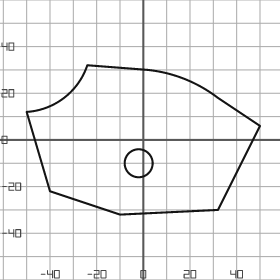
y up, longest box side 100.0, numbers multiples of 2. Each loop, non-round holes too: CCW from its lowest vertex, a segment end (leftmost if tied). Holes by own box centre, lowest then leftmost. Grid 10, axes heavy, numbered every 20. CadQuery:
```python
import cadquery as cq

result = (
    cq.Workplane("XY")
    .moveTo(-10.0, -32.0)
    .lineTo(32.0, -30.0)
    .lineTo(50.0, 6.0)
    .lineTo(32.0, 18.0)
    .threePointArc((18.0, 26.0), (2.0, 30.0))
    .lineTo(-24.0, 32.0)
    .threePointArc((-34.0, 18.0), (-50.0, 12.0))
    .lineTo(-40.0, -22.0)
    .close()
    .moveTo(-2.0, -10.0)
    .circle(6.0)
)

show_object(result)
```